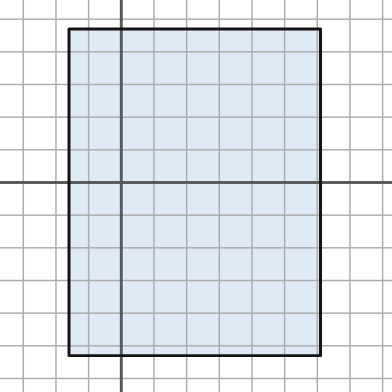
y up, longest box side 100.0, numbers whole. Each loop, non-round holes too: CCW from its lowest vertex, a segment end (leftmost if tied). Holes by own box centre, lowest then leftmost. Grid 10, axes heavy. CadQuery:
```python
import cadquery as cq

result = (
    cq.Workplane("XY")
    .moveTo(-16.0, -53.0)
    .lineTo(61.0, -53.0)
    .lineTo(61.0, 47.0)
    .lineTo(-16.0, 47.0)
    .close()
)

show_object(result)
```